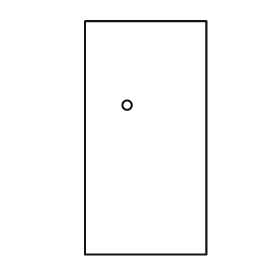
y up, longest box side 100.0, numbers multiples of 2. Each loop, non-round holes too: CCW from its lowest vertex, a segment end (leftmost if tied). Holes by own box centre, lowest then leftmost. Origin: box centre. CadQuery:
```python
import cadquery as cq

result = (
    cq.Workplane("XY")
    .moveTo(-26.0, -50.0)
    .lineTo(26.0, -50.0)
    .lineTo(26.0, 50.0)
    .lineTo(-26.0, 50.0)
    .close()
    .moveTo(-8.0, 14.0)
    .circle(2.0)
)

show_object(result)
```